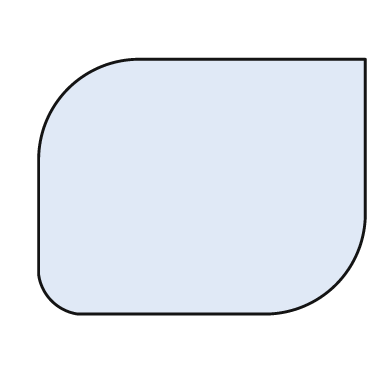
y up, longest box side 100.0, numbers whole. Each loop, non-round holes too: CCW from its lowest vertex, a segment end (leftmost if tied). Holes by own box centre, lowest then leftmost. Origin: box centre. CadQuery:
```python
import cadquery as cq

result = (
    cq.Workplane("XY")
    .moveTo(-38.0, -39.0)
    .lineTo(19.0, -39.0)
    .threePointArc((41.0, -30.0), (50.0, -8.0))
    .lineTo(50.0, 39.0)
    .lineTo(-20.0, 39.0)
    .threePointArc((-41.0, 30.0), (-50.0, 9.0))
    .lineTo(-50.0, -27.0)
    .threePointArc((-46.0, -35.0), (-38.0, -39.0))
    .close()
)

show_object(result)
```